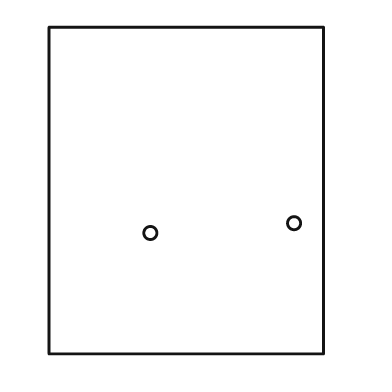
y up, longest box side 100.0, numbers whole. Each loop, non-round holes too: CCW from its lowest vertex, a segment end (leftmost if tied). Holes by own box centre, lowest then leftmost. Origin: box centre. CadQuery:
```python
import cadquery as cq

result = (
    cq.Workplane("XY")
    .moveTo(-42.0, -50.0)
    .lineTo(42.0, -50.0)
    .lineTo(42.0, 50.0)
    .lineTo(-42.0, 50.0)
    .close()
    .moveTo(-11.0, -13.0)
    .circle(2.0)
    .moveTo(33.0, -10.0)
    .circle(2.0)
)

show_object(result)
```